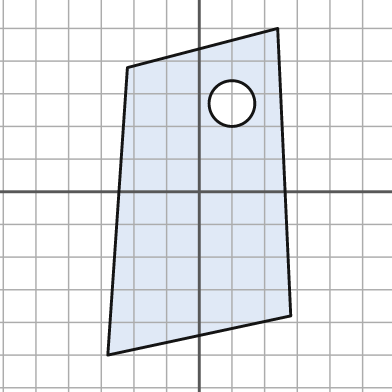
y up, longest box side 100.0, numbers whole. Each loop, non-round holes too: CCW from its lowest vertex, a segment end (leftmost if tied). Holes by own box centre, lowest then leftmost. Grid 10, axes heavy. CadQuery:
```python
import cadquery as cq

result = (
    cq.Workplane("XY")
    .moveTo(-28.0, -50.0)
    .lineTo(28.0, -38.0)
    .lineTo(24.0, 50.0)
    .lineTo(-22.0, 38.0)
    .close()
    .moveTo(10.0, 27.0)
    .circle(7.0)
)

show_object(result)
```